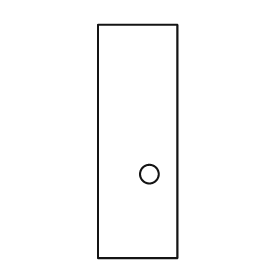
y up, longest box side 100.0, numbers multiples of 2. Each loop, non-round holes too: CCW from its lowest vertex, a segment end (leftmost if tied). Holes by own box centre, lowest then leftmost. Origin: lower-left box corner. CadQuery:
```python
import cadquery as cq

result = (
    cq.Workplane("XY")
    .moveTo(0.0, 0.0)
    .lineTo(34.0, 0.0)
    .lineTo(34.0, 100.0)
    .lineTo(0.0, 100.0)
    .close()
    .moveTo(22.0, 36.0)
    .circle(4.0)
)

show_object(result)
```